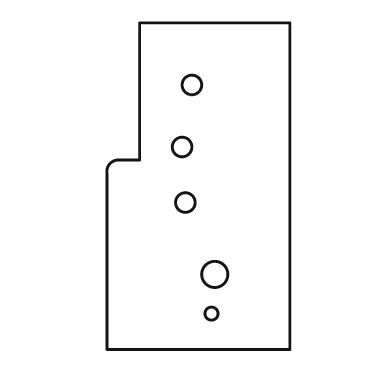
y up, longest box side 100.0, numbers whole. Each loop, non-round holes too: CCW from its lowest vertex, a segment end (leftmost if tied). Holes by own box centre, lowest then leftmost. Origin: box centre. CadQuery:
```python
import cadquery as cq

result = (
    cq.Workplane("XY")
    .moveTo(-28.0, -50.0)
    .lineTo(28.0, -50.0)
    .lineTo(28.0, 50.0)
    .lineTo(-18.0, 50.0)
    .lineTo(-18.0, 8.0)
    .lineTo(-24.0, 8.0)
    .threePointArc((-27.0, 7.0), (-28.0, 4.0))
    .close()
    .moveTo(4.0, -39.0)
    .circle(2.0)
    .moveTo(5.0, -27.0)
    .circle(4.0)
    .moveTo(-4.0, -5.0)
    .circle(3.0)
    .moveTo(-5.0, 12.0)
    .circle(3.0)
    .moveTo(-2.0, 31.0)
    .circle(3.0)
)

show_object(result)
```